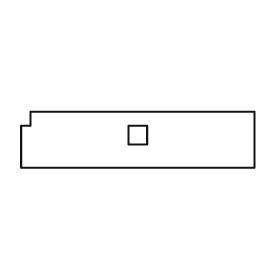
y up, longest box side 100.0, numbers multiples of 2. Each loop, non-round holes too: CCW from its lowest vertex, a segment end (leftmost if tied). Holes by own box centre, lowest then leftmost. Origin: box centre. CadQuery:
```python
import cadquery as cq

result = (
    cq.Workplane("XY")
    .moveTo(-50.0, -12.0)
    .lineTo(50.0, -12.0)
    .lineTo(50.0, 12.0)
    .lineTo(-46.0, 12.0)
    .lineTo(-46.0, 6.0)
    .lineTo(-50.0, 6.0)
    .close()
    .moveTo(-4.0, -2.0)
    .lineTo(4.0, -2.0)
    .lineTo(4.0, 6.0)
    .lineTo(-4.0, 6.0)
    .close()
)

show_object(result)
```